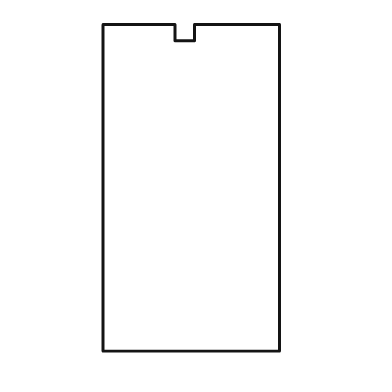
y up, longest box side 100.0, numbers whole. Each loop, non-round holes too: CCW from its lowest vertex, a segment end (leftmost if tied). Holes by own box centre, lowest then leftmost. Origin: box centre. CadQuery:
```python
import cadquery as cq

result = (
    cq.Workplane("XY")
    .moveTo(-27.0, -50.0)
    .lineTo(27.0, -50.0)
    .lineTo(27.0, 50.0)
    .lineTo(1.0, 50.0)
    .lineTo(1.0, 45.0)
    .lineTo(-5.0, 45.0)
    .lineTo(-5.0, 50.0)
    .lineTo(-27.0, 50.0)
    .close()
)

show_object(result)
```